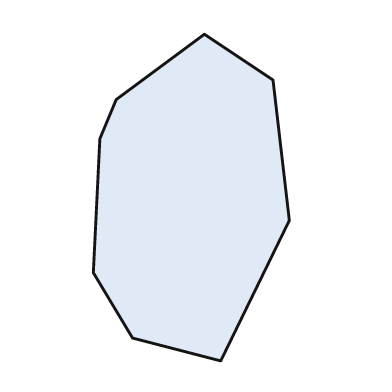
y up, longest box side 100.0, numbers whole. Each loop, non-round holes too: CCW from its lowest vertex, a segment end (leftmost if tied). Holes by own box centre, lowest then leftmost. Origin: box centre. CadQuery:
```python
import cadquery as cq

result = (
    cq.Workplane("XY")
    .moveTo(9.0, -50.0)
    .lineTo(30.0, -7.0)
    .lineTo(25.0, 36.0)
    .lineTo(4.0, 50.0)
    .lineTo(-23.0, 30.0)
    .lineTo(-28.0, 18.0)
    .lineTo(-30.0, -23.0)
    .lineTo(-18.0, -43.0)
    .close()
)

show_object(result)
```